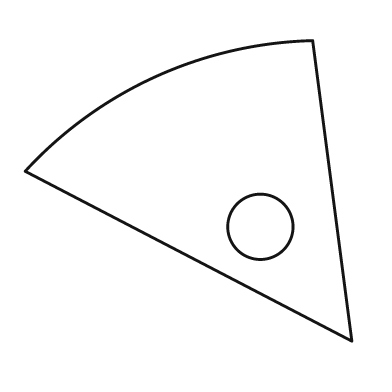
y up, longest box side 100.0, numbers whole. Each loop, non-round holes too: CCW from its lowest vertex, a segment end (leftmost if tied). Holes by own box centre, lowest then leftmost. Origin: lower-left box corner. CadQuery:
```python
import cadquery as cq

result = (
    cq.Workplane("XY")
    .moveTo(100.0, 0.0)
    .lineTo(88.0, 92.0)
    .threePointArc((40.0, 81.0), (0.0, 52.0))
    .close()
    .moveTo(72.0, 35.0)
    .circle(10.0)
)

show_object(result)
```